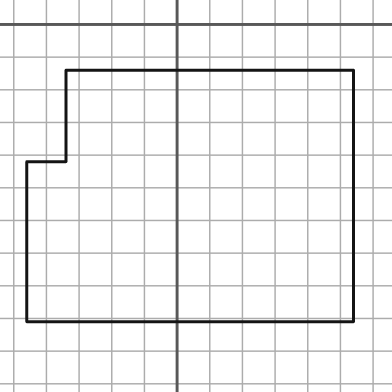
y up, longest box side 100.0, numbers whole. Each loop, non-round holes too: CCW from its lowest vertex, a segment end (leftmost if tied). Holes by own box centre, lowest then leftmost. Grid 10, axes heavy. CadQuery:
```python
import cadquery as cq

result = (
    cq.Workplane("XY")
    .moveTo(-46.0, -91.0)
    .lineTo(54.0, -91.0)
    .lineTo(54.0, -14.0)
    .lineTo(-34.0, -14.0)
    .lineTo(-34.0, -42.0)
    .lineTo(-46.0, -42.0)
    .close()
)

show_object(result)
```